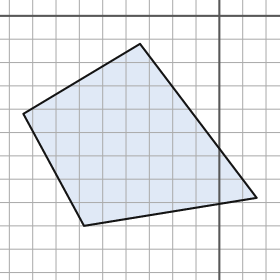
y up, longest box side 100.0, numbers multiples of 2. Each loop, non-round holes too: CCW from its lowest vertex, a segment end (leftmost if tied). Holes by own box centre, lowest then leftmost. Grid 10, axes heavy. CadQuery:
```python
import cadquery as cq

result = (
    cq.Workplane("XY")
    .moveTo(-58.0, -90.0)
    .lineTo(16.0, -78.0)
    .lineTo(-34.0, -12.0)
    .lineTo(-84.0, -42.0)
    .close()
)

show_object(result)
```